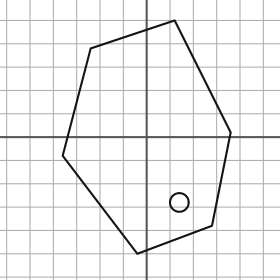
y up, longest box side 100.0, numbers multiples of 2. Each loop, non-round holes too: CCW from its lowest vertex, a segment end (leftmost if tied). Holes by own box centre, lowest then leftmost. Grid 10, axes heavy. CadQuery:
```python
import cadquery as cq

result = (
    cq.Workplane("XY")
    .moveTo(-4.0, -50.0)
    .lineTo(28.0, -38.0)
    .lineTo(36.0, 2.0)
    .lineTo(12.0, 50.0)
    .lineTo(-24.0, 38.0)
    .lineTo(-36.0, -8.0)
    .close()
    .moveTo(14.0, -28.0)
    .circle(4.0)
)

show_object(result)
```